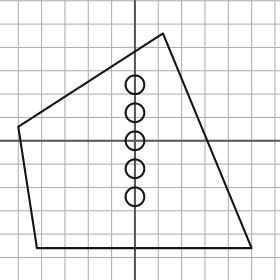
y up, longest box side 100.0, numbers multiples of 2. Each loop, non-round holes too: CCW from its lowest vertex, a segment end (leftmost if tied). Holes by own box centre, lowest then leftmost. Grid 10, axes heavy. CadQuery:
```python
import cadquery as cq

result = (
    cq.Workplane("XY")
    .moveTo(-42.0, -46.0)
    .lineTo(50.0, -46.0)
    .lineTo(12.0, 46.0)
    .lineTo(-50.0, 6.0)
    .close()
    .moveTo(0.0, -24.0)
    .circle(4.0)
    .moveTo(0.0, -12.0)
    .circle(4.0)
    .moveTo(0.0, 0.0)
    .circle(4.0)
    .moveTo(0.0, 12.0)
    .circle(4.0)
    .moveTo(0.0, 24.0)
    .circle(4.0)
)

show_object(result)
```